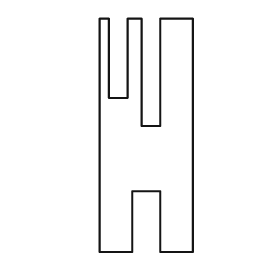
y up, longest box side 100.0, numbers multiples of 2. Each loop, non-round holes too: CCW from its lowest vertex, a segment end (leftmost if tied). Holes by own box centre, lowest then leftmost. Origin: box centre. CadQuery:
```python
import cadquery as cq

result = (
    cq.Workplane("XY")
    .moveTo(-20.0, -50.0)
    .lineTo(-6.0, -50.0)
    .lineTo(-6.0, -24.0)
    .lineTo(6.0, -24.0)
    .lineTo(6.0, -50.0)
    .lineTo(20.0, -50.0)
    .lineTo(20.0, 50.0)
    .lineTo(6.0, 50.0)
    .lineTo(6.0, 4.0)
    .lineTo(-2.0, 4.0)
    .lineTo(-2.0, 50.0)
    .lineTo(-8.0, 50.0)
    .lineTo(-8.0, 16.0)
    .lineTo(-16.0, 16.0)
    .lineTo(-16.0, 50.0)
    .lineTo(-20.0, 50.0)
    .close()
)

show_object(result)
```